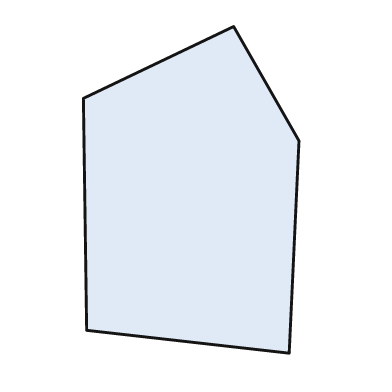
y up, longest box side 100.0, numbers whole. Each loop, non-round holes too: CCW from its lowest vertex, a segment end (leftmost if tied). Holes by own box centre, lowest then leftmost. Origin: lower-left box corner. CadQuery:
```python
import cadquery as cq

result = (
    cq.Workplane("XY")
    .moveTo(63.0, 0.0)
    .lineTo(66.0, 65.0)
    .lineTo(46.0, 100.0)
    .lineTo(0.0, 78.0)
    .lineTo(1.0, 7.0)
    .close()
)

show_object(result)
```